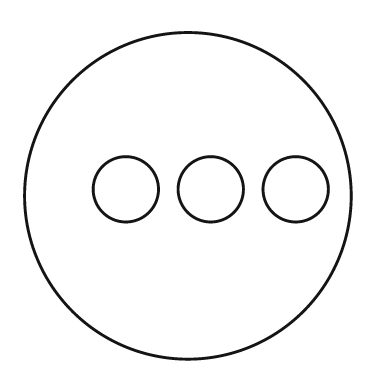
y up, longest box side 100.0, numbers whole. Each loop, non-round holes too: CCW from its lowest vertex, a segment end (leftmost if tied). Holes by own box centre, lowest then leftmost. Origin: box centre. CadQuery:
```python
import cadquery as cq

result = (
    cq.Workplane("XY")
    .moveTo(0.0, 0.0)
    .circle(50.0)
    .moveTo(-19.0, 2.0)
    .circle(10.0)
    .moveTo(7.0, 2.0)
    .circle(10.0)
    .moveTo(33.0, 2.0)
    .circle(10.0)
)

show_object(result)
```